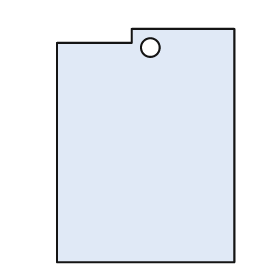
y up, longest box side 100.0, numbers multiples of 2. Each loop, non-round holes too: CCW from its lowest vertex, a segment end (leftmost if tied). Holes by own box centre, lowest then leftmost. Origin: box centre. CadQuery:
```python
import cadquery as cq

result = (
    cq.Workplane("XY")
    .moveTo(-38.0, -50.0)
    .lineTo(38.0, -50.0)
    .lineTo(38.0, 50.0)
    .lineTo(-6.0, 50.0)
    .lineTo(-6.0, 44.0)
    .lineTo(-38.0, 44.0)
    .close()
    .moveTo(2.0, 42.0)
    .circle(4.0)
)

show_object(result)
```